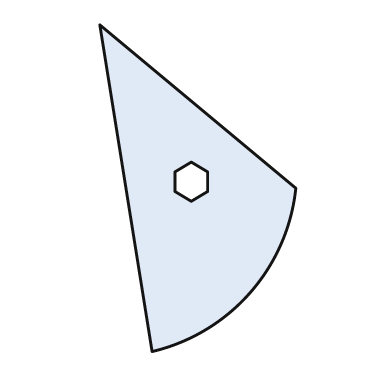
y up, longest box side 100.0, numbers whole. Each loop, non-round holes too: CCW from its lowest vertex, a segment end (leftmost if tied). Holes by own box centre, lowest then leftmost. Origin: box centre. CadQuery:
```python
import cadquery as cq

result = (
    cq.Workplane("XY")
    .moveTo(-14.0, -50.0)
    .threePointArc((16.0, -32.0), (30.0, 0.0))
    .lineTo(-30.0, 50.0)
    .close()
    .moveTo(-2.0, -4.0)
    .lineTo(3.0, -1.0)
    .lineTo(3.0, 5.0)
    .lineTo(-2.0, 8.0)
    .lineTo(-7.0, 5.0)
    .lineTo(-7.0, -1.0)
    .close()
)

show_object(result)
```